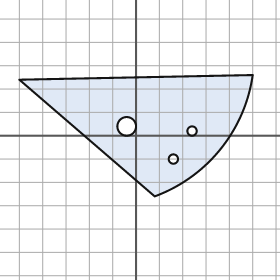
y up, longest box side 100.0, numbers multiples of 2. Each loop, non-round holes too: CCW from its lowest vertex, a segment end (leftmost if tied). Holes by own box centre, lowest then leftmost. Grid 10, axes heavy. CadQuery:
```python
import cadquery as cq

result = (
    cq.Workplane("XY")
    .moveTo(8.0, -26.0)
    .threePointArc((36.0, -6.0), (50.0, 26.0))
    .lineTo(-50.0, 24.0)
    .close()
    .moveTo(16.0, -10.0)
    .circle(2.0)
    .moveTo(24.0, 2.0)
    .circle(2.0)
    .moveTo(-4.0, 4.0)
    .circle(4.0)
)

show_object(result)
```